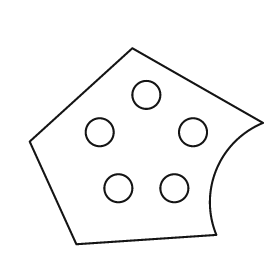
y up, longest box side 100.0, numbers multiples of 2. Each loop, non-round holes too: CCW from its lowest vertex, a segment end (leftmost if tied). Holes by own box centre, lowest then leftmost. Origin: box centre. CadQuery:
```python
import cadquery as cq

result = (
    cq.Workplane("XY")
    .moveTo(-30.0, -42.0)
    .lineTo(30.0, -38.0)
    .threePointArc((30.0, -10.0), (50.0, 10.0))
    .lineTo(-6.0, 42.0)
    .lineTo(-50.0, 2.0)
    .close()
    .moveTo(-12.0, -18.0)
    .circle(6.0)
    .moveTo(12.0, -18.0)
    .circle(6.0)
    .moveTo(-20.0, 6.0)
    .circle(6.0)
    .moveTo(20.0, 6.0)
    .circle(6.0)
    .moveTo(0.0, 22.0)
    .circle(6.0)
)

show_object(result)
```